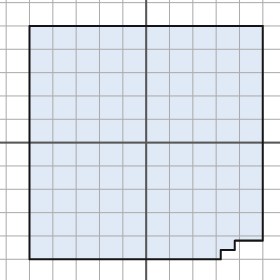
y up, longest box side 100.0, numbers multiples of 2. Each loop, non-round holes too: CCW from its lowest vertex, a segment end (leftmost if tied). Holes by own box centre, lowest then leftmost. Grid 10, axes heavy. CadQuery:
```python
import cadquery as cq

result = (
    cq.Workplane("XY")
    .moveTo(-50.0, -50.0)
    .lineTo(32.0, -50.0)
    .lineTo(32.0, -46.0)
    .lineTo(38.0, -46.0)
    .lineTo(38.0, -42.0)
    .lineTo(50.0, -42.0)
    .lineTo(50.0, 50.0)
    .lineTo(-50.0, 50.0)
    .close()
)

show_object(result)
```